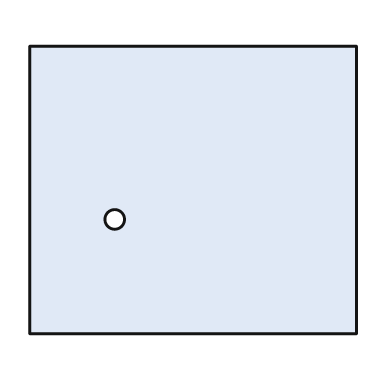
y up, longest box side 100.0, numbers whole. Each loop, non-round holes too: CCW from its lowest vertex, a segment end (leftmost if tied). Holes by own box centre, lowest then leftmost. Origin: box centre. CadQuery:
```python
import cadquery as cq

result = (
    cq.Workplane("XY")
    .moveTo(-50.0, -44.0)
    .lineTo(50.0, -44.0)
    .lineTo(50.0, 44.0)
    .lineTo(-50.0, 44.0)
    .close()
    .moveTo(-24.0, -9.0)
    .circle(3.0)
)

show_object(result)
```